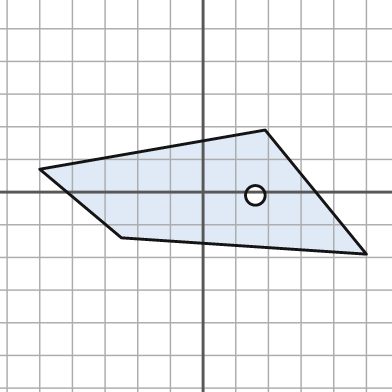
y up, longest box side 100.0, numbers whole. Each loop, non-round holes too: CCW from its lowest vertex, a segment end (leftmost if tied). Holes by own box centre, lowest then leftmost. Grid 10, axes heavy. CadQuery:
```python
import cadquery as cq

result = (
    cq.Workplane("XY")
    .moveTo(50.0, -19.0)
    .lineTo(19.0, 19.0)
    .lineTo(-50.0, 7.0)
    .lineTo(-25.0, -14.0)
    .close()
    .moveTo(16.0, -1.0)
    .circle(3.0)
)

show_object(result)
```